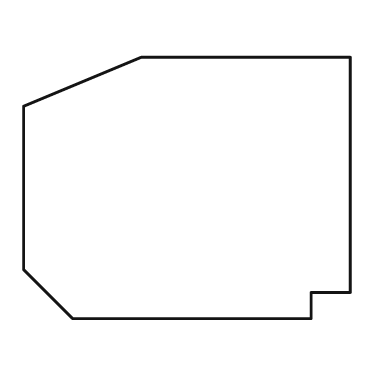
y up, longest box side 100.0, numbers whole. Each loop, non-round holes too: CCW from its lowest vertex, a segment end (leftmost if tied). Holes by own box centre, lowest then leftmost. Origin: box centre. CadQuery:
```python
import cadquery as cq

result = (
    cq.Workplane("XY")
    .moveTo(-35.0, -40.0)
    .lineTo(38.0, -40.0)
    .lineTo(38.0, -32.0)
    .lineTo(50.0, -32.0)
    .lineTo(50.0, 40.0)
    .lineTo(-14.0, 40.0)
    .lineTo(-50.0, 25.0)
    .lineTo(-50.0, -25.0)
    .close()
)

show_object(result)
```